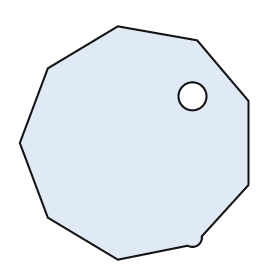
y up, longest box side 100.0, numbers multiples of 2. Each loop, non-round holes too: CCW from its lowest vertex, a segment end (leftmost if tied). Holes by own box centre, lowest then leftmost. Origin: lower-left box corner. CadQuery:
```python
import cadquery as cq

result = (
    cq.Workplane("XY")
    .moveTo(42.0, 0.0)
    .lineTo(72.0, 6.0)
    .threePointArc((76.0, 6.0), (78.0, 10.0))
    .lineTo(98.0, 32.0)
    .lineTo(98.0, 68.0)
    .lineTo(76.0, 94.0)
    .lineTo(42.0, 100.0)
    .lineTo(12.0, 82.0)
    .lineTo(0.0, 50.0)
    .lineTo(12.0, 18.0)
    .close()
    .moveTo(74.0, 70.0)
    .circle(6.0)
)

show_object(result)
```